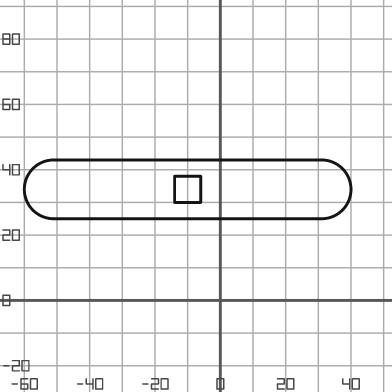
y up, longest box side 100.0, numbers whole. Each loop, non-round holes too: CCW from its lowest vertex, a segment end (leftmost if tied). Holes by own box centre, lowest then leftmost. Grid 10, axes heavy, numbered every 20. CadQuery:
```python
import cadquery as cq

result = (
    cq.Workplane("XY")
    .moveTo(-51.0, 25.0)
    .lineTo(31.0, 25.0)
    .threePointArc((40.0, 34.0), (31.0, 43.0))
    .lineTo(-51.0, 43.0)
    .threePointArc((-60.0, 34.0), (-51.0, 25.0))
    .close()
    .moveTo(-14.0, 30.0)
    .lineTo(-6.0, 30.0)
    .lineTo(-6.0, 38.0)
    .lineTo(-14.0, 38.0)
    .close()
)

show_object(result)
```